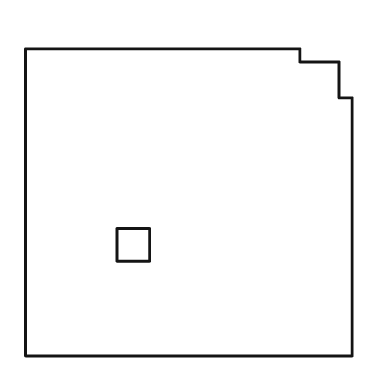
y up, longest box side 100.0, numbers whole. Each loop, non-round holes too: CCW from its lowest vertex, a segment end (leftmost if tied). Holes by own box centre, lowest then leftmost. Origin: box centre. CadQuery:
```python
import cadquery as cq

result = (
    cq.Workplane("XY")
    .moveTo(-50.0, -47.0)
    .lineTo(50.0, -47.0)
    .lineTo(50.0, 32.0)
    .lineTo(46.0, 32.0)
    .lineTo(46.0, 43.0)
    .lineTo(34.0, 43.0)
    .lineTo(34.0, 47.0)
    .lineTo(-50.0, 47.0)
    .close()
    .moveTo(-22.0, -18.0)
    .lineTo(-12.0, -18.0)
    .lineTo(-12.0, -8.0)
    .lineTo(-22.0, -8.0)
    .close()
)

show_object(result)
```